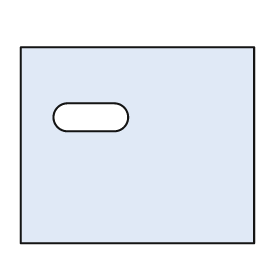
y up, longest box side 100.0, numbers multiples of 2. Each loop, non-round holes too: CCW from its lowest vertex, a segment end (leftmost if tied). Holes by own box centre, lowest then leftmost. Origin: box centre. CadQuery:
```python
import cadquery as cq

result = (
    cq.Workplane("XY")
    .moveTo(-50.0, -42.0)
    .lineTo(50.0, -42.0)
    .lineTo(50.0, 42.0)
    .lineTo(-50.0, 42.0)
    .close()
    .moveTo(-30.0, 6.0)
    .lineTo(-10.0, 6.0)
    .threePointArc((-4.0, 12.0), (-10.0, 18.0))
    .lineTo(-30.0, 18.0)
    .threePointArc((-36.0, 12.0), (-30.0, 6.0))
    .close()
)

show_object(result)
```